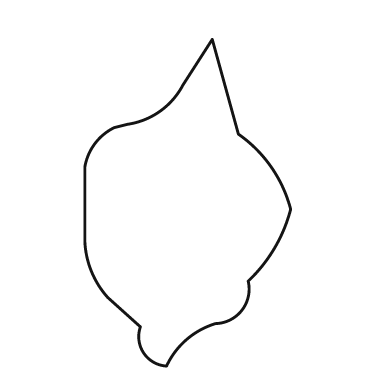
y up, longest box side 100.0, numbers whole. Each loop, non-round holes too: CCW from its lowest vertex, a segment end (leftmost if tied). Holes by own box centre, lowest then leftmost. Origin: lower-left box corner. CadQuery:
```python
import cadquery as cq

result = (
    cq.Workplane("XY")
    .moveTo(25.0, 0.0)
    .threePointArc((31.0, 8.0), (40.0, 13.0))
    .threePointArc((48.0, 17.0), (50.0, 26.0))
    .threePointArc((58.0, 36.0), (63.0, 48.0))
    .threePointArc((57.0, 61.0), (47.0, 71.0))
    .lineTo(39.0, 100.0)
    .lineTo(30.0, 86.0)
    .threePointArc((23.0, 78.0), (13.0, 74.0))
    .lineTo(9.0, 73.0)
    .threePointArc((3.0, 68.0), (0.0, 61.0))
    .lineTo(0.0, 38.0)
    .threePointArc((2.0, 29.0), (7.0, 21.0))
    .lineTo(17.0, 12.0)
    .threePointArc((18.0, 4.0), (25.0, 0.0))
    .close()
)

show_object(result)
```